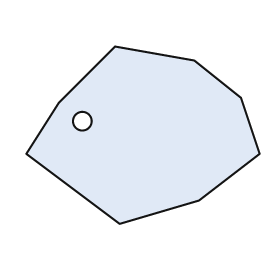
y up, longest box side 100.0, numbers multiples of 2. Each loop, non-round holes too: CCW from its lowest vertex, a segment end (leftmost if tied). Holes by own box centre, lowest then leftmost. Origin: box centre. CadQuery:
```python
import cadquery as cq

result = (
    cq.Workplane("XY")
    .moveTo(-10.0, -38.0)
    .lineTo(24.0, -28.0)
    .lineTo(50.0, -8.0)
    .lineTo(42.0, 16.0)
    .lineTo(22.0, 32.0)
    .lineTo(-12.0, 38.0)
    .lineTo(-36.0, 14.0)
    .lineTo(-50.0, -8.0)
    .close()
    .moveTo(-26.0, 6.0)
    .circle(4.0)
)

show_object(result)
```